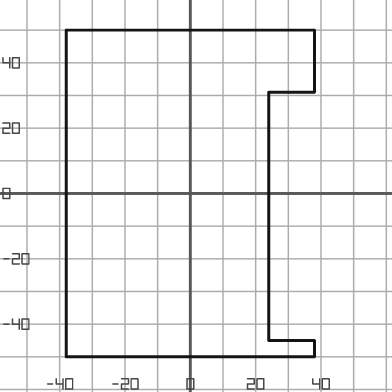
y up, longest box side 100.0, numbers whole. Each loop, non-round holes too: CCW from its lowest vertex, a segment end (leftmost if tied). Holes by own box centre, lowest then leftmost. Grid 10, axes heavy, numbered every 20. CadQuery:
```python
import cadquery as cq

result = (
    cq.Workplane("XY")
    .moveTo(-38.0, -50.0)
    .lineTo(38.0, -50.0)
    .lineTo(38.0, -45.0)
    .lineTo(24.0, -45.0)
    .lineTo(24.0, 31.0)
    .lineTo(38.0, 31.0)
    .lineTo(38.0, 50.0)
    .lineTo(-38.0, 50.0)
    .close()
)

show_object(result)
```